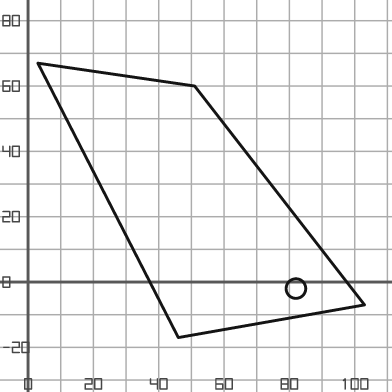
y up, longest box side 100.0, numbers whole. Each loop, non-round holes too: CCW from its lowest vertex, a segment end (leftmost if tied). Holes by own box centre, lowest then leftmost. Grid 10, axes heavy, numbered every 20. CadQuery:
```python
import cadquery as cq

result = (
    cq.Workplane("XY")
    .moveTo(46.0, -17.0)
    .lineTo(103.0, -7.0)
    .lineTo(51.0, 60.0)
    .lineTo(3.0, 67.0)
    .close()
    .moveTo(82.0, -2.0)
    .circle(3.0)
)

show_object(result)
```